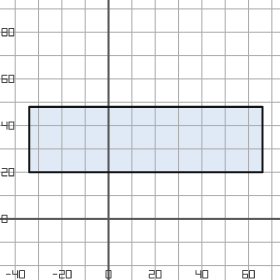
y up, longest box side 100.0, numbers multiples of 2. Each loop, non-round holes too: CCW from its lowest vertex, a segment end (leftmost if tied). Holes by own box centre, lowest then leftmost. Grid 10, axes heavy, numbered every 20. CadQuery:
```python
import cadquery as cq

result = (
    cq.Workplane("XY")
    .moveTo(-34.0, 20.0)
    .lineTo(66.0, 20.0)
    .lineTo(66.0, 48.0)
    .lineTo(-34.0, 48.0)
    .close()
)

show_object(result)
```